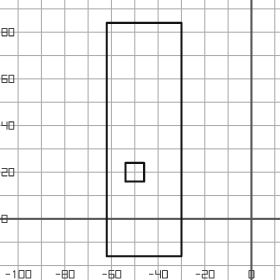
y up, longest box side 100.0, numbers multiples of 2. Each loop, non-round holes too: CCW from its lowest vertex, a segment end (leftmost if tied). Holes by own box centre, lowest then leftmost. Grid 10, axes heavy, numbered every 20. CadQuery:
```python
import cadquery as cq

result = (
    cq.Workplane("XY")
    .moveTo(-62.0, -16.0)
    .lineTo(-30.0, -16.0)
    .lineTo(-30.0, 84.0)
    .lineTo(-62.0, 84.0)
    .close()
    .moveTo(-54.0, 16.0)
    .lineTo(-46.0, 16.0)
    .lineTo(-46.0, 24.0)
    .lineTo(-54.0, 24.0)
    .close()
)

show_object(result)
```